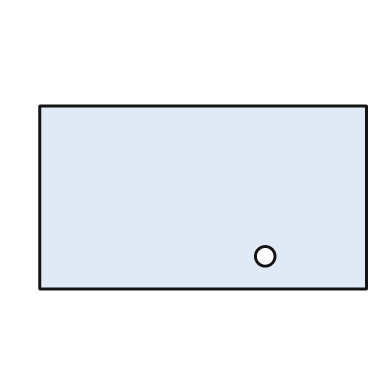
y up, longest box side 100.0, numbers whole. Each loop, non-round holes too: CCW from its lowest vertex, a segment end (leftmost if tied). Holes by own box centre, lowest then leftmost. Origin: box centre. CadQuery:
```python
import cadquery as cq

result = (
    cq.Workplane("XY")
    .moveTo(-50.0, -28.0)
    .lineTo(50.0, -28.0)
    .lineTo(50.0, 28.0)
    .lineTo(-50.0, 28.0)
    .close()
    .moveTo(19.0, -18.0)
    .circle(3.0)
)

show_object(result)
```